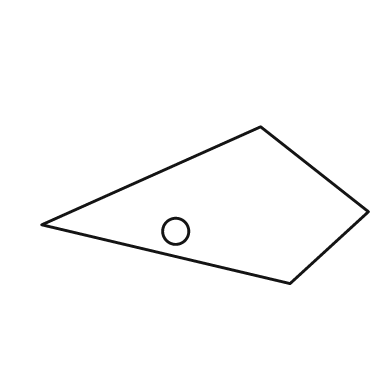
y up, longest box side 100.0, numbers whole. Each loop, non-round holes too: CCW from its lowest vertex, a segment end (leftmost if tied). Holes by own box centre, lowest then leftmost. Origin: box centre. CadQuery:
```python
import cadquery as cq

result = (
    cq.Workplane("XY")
    .moveTo(26.0, -24.0)
    .lineTo(50.0, -2.0)
    .lineTo(17.0, 24.0)
    .lineTo(-50.0, -6.0)
    .close()
    .moveTo(-9.0, -8.0)
    .circle(4.0)
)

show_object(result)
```